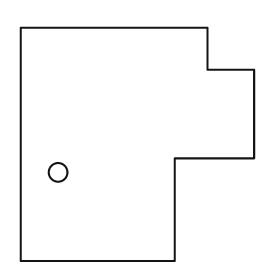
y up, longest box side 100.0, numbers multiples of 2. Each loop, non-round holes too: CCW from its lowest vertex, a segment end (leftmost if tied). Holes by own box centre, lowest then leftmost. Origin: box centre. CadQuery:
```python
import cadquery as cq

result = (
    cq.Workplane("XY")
    .moveTo(-50.0, -50.0)
    .lineTo(16.0, -50.0)
    .lineTo(16.0, -6.0)
    .lineTo(50.0, -6.0)
    .lineTo(50.0, 32.0)
    .lineTo(30.0, 32.0)
    .lineTo(30.0, 50.0)
    .lineTo(-50.0, 50.0)
    .close()
    .moveTo(-34.0, -12.0)
    .circle(4.0)
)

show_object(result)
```